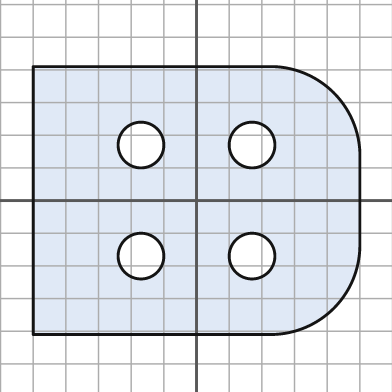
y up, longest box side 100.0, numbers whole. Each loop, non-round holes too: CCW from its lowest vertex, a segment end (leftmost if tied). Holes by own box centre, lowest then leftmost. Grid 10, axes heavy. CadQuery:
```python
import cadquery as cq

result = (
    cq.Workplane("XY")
    .moveTo(-50.0, -41.0)
    .lineTo(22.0, -41.0)
    .threePointArc((42.0, -33.0), (50.0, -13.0))
    .lineTo(50.0, 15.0)
    .threePointArc((42.0, 33.0), (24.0, 41.0))
    .lineTo(-50.0, 41.0)
    .close()
    .moveTo(-17.0, -17.0)
    .circle(7.0)
    .moveTo(17.0, -17.0)
    .circle(7.0)
    .moveTo(-17.0, 17.0)
    .circle(7.0)
    .moveTo(17.0, 17.0)
    .circle(7.0)
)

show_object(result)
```